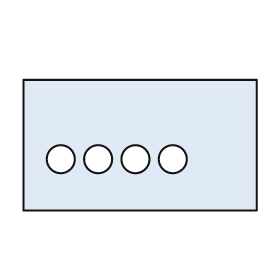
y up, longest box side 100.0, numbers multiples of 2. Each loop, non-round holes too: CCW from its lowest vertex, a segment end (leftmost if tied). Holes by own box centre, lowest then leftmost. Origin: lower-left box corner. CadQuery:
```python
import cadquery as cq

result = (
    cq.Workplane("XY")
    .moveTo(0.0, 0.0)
    .lineTo(100.0, 0.0)
    .lineTo(100.0, 56.0)
    .lineTo(0.0, 56.0)
    .close()
    .moveTo(16.0, 22.0)
    .circle(6.0)
    .moveTo(32.0, 22.0)
    .circle(6.0)
    .moveTo(48.0, 22.0)
    .circle(6.0)
    .moveTo(64.0, 22.0)
    .circle(6.0)
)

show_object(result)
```